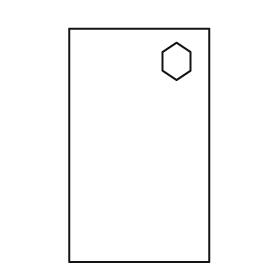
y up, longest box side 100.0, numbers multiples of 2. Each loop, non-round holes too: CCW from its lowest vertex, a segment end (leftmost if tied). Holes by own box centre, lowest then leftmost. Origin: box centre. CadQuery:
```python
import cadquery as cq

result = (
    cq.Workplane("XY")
    .moveTo(-30.0, -50.0)
    .lineTo(30.0, -50.0)
    .lineTo(30.0, 50.0)
    .lineTo(-30.0, 50.0)
    .close()
    .moveTo(16.0, 28.0)
    .lineTo(22.0, 32.0)
    .lineTo(22.0, 40.0)
    .lineTo(16.0, 44.0)
    .lineTo(10.0, 40.0)
    .lineTo(10.0, 32.0)
    .close()
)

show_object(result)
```